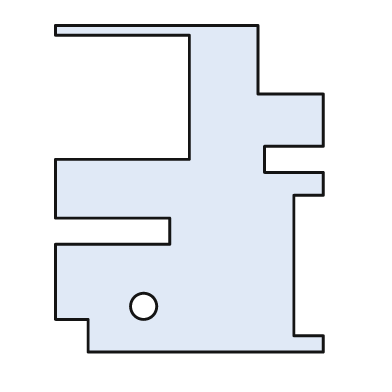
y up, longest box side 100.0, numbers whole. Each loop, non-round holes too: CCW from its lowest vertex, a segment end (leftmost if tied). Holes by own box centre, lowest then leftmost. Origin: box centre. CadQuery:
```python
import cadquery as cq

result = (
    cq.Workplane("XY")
    .moveTo(-31.0, -50.0)
    .lineTo(41.0, -50.0)
    .lineTo(41.0, -45.0)
    .lineTo(32.0, -45.0)
    .lineTo(32.0, -2.0)
    .lineTo(41.0, -2.0)
    .lineTo(41.0, 5.0)
    .lineTo(23.0, 5.0)
    .lineTo(23.0, 13.0)
    .lineTo(41.0, 13.0)
    .lineTo(41.0, 29.0)
    .lineTo(21.0, 29.0)
    .lineTo(21.0, 50.0)
    .lineTo(-41.0, 50.0)
    .lineTo(-41.0, 47.0)
    .lineTo(0.0, 47.0)
    .lineTo(0.0, 9.0)
    .lineTo(-41.0, 9.0)
    .lineTo(-41.0, -9.0)
    .lineTo(-6.0, -9.0)
    .lineTo(-6.0, -17.0)
    .lineTo(-41.0, -17.0)
    .lineTo(-41.0, -40.0)
    .lineTo(-31.0, -40.0)
    .close()
    .moveTo(-14.0, -36.0)
    .circle(4.0)
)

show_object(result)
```